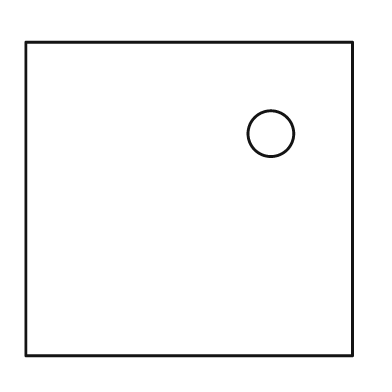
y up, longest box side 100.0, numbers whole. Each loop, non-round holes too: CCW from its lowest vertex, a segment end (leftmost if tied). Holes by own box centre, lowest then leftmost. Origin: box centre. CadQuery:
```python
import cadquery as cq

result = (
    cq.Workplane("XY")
    .moveTo(-50.0, -48.0)
    .lineTo(50.0, -48.0)
    .lineTo(50.0, 48.0)
    .lineTo(-50.0, 48.0)
    .close()
    .moveTo(25.0, 20.0)
    .circle(7.0)
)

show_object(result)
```